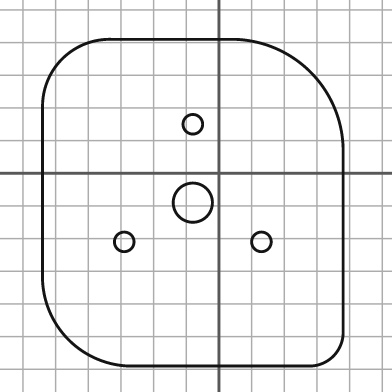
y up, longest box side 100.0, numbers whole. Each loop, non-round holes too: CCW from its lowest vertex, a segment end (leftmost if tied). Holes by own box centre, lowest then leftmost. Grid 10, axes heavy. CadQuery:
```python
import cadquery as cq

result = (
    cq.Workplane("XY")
    .moveTo(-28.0, -59.0)
    .lineTo(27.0, -59.0)
    .threePointArc((35.0, -56.0), (38.0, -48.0))
    .lineTo(38.0, 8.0)
    .threePointArc((28.0, 31.0), (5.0, 41.0))
    .lineTo(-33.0, 41.0)
    .threePointArc((-48.0, 35.0), (-54.0, 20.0))
    .lineTo(-54.0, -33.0)
    .threePointArc((-46.0, -51.0), (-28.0, -59.0))
    .close()
    .moveTo(-29.0, -21.0)
    .circle(3.0)
    .moveTo(13.0, -21.0)
    .circle(3.0)
    .moveTo(-8.0, -9.0)
    .circle(6.0)
    .moveTo(-8.0, 15.0)
    .circle(3.0)
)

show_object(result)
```